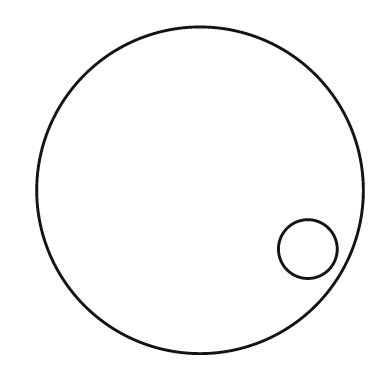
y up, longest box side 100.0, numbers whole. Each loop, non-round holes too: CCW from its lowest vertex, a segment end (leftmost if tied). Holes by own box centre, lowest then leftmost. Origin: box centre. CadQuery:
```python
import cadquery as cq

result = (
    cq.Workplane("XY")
    .moveTo(0.0, 0.0)
    .circle(50.0)
    .moveTo(33.0, -18.0)
    .circle(9.0)
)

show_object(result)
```